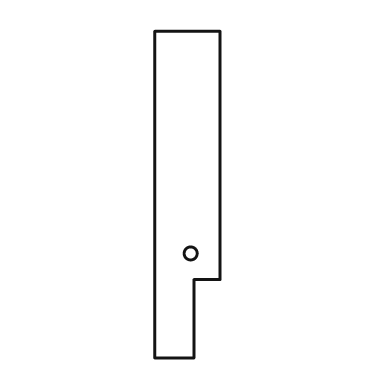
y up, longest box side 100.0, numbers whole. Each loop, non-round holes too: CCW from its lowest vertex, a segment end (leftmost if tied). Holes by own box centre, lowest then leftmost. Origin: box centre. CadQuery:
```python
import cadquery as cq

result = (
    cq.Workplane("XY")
    .moveTo(-10.0, -50.0)
    .lineTo(2.0, -50.0)
    .lineTo(2.0, -26.0)
    .lineTo(10.0, -26.0)
    .lineTo(10.0, 50.0)
    .lineTo(-10.0, 50.0)
    .close()
    .moveTo(1.0, -18.0)
    .circle(2.0)
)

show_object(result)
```